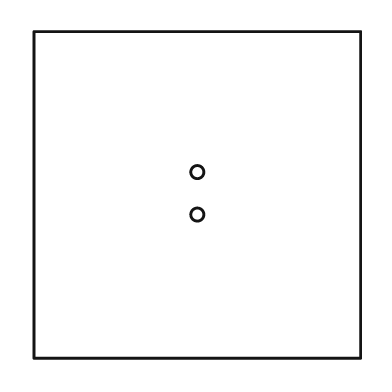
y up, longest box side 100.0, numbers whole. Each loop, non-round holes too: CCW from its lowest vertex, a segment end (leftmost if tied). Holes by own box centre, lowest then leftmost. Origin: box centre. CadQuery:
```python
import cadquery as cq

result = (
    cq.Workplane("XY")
    .moveTo(-50.0, -50.0)
    .lineTo(50.0, -50.0)
    .lineTo(50.0, 50.0)
    .lineTo(-50.0, 50.0)
    .close()
    .moveTo(0.0, -6.0)
    .circle(2.0)
    .moveTo(0.0, 7.0)
    .circle(2.0)
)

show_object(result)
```